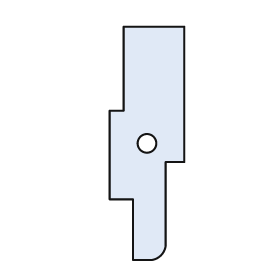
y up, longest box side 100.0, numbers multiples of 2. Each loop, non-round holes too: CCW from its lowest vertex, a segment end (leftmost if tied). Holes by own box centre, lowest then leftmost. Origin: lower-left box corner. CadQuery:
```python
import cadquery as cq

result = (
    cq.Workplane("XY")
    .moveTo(10.0, 0.0)
    .lineTo(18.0, 0.0)
    .threePointArc((22.0, 2.0), (24.0, 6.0))
    .lineTo(24.0, 42.0)
    .lineTo(32.0, 42.0)
    .lineTo(32.0, 100.0)
    .lineTo(6.0, 100.0)
    .lineTo(6.0, 64.0)
    .lineTo(0.0, 64.0)
    .lineTo(0.0, 26.0)
    .lineTo(10.0, 26.0)
    .close()
    .moveTo(16.0, 50.0)
    .circle(4.0)
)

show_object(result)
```